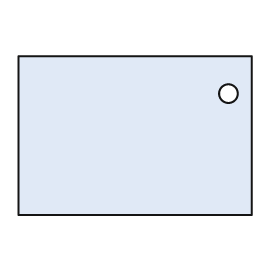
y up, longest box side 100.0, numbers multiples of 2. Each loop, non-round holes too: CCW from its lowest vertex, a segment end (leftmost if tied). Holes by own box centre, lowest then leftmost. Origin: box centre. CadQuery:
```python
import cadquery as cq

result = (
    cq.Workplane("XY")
    .moveTo(-50.0, -34.0)
    .lineTo(50.0, -34.0)
    .lineTo(50.0, 34.0)
    .lineTo(-50.0, 34.0)
    .close()
    .moveTo(40.0, 18.0)
    .circle(4.0)
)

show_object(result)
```